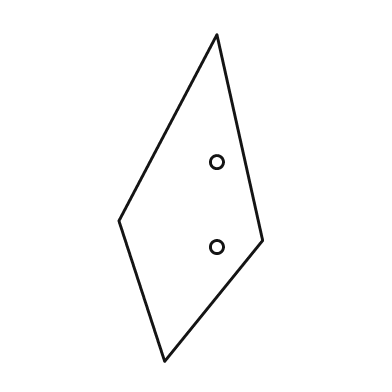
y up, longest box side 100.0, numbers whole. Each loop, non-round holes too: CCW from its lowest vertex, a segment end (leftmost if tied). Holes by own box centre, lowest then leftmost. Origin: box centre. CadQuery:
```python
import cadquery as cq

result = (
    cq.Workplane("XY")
    .moveTo(-8.0, -50.0)
    .lineTo(22.0, -13.0)
    .lineTo(8.0, 50.0)
    .lineTo(-22.0, -7.0)
    .close()
    .moveTo(8.0, -15.0)
    .circle(2.0)
    .moveTo(8.0, 11.0)
    .circle(2.0)
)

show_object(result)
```